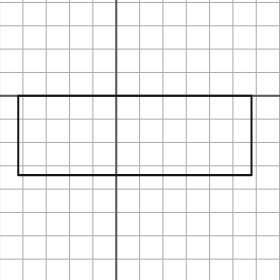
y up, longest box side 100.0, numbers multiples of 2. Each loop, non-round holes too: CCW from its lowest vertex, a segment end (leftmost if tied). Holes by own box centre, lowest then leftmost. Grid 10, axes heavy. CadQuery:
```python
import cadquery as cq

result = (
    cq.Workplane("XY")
    .moveTo(-42.0, -34.0)
    .lineTo(58.0, -34.0)
    .lineTo(58.0, 0.0)
    .lineTo(-42.0, 0.0)
    .close()
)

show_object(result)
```